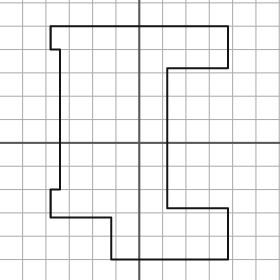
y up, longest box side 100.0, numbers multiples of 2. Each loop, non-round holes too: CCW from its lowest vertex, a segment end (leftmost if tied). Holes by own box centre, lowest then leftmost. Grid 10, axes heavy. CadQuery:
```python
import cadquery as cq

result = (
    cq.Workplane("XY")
    .moveTo(-12.0, -50.0)
    .lineTo(38.0, -50.0)
    .lineTo(38.0, -28.0)
    .lineTo(12.0, -28.0)
    .lineTo(12.0, 32.0)
    .lineTo(38.0, 32.0)
    .lineTo(38.0, 50.0)
    .lineTo(-38.0, 50.0)
    .lineTo(-38.0, 40.0)
    .lineTo(-34.0, 40.0)
    .lineTo(-34.0, -20.0)
    .lineTo(-38.0, -20.0)
    .lineTo(-38.0, -32.0)
    .lineTo(-12.0, -32.0)
    .close()
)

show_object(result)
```